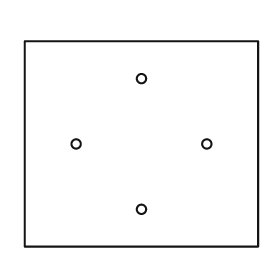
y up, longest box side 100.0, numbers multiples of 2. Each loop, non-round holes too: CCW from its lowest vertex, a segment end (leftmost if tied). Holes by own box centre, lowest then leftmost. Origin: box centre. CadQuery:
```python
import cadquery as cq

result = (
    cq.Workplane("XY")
    .moveTo(-50.0, -44.0)
    .lineTo(50.0, -44.0)
    .lineTo(50.0, 44.0)
    .lineTo(-50.0, 44.0)
    .close()
    .moveTo(0.0, -28.0)
    .circle(2.0)
    .moveTo(-28.0, 0.0)
    .circle(2.0)
    .moveTo(28.0, 0.0)
    .circle(2.0)
    .moveTo(0.0, 28.0)
    .circle(2.0)
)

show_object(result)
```